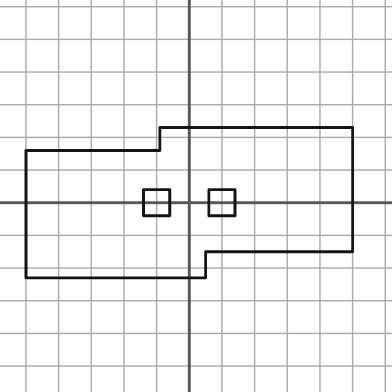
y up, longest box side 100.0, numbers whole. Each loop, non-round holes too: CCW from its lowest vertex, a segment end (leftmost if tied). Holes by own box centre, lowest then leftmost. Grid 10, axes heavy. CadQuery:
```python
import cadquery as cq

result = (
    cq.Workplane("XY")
    .moveTo(-50.0, -23.0)
    .lineTo(5.0, -23.0)
    .lineTo(5.0, -15.0)
    .lineTo(50.0, -15.0)
    .lineTo(50.0, 23.0)
    .lineTo(-9.0, 23.0)
    .lineTo(-9.0, 16.0)
    .lineTo(-50.0, 16.0)
    .close()
    .moveTo(-14.0, -4.0)
    .lineTo(-6.0, -4.0)
    .lineTo(-6.0, 4.0)
    .lineTo(-14.0, 4.0)
    .close()
    .moveTo(6.0, -4.0)
    .lineTo(14.0, -4.0)
    .lineTo(14.0, 4.0)
    .lineTo(6.0, 4.0)
    .close()
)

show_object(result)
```